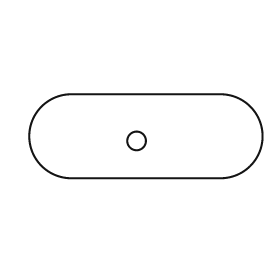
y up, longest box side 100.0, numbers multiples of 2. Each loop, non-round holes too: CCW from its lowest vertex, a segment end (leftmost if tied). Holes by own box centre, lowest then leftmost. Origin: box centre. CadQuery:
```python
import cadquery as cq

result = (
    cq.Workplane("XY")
    .moveTo(-32.0, -18.0)
    .lineTo(32.0, -18.0)
    .threePointArc((50.0, 0.0), (32.0, 18.0))
    .lineTo(-32.0, 18.0)
    .threePointArc((-50.0, 0.0), (-32.0, -18.0))
    .close()
    .moveTo(-4.0, -2.0)
    .circle(4.0)
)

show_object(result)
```